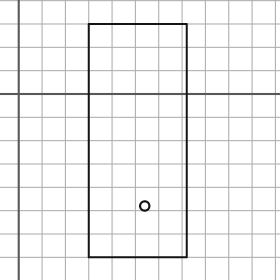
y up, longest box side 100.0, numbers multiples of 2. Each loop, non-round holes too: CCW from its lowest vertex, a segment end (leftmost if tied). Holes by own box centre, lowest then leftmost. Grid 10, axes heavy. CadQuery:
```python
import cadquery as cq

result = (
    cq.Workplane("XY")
    .moveTo(30.0, -70.0)
    .lineTo(72.0, -70.0)
    .lineTo(72.0, 30.0)
    .lineTo(30.0, 30.0)
    .close()
    .moveTo(54.0, -48.0)
    .circle(2.0)
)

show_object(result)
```